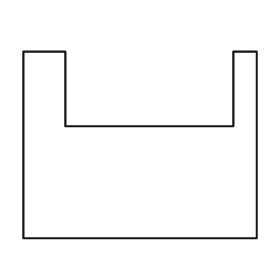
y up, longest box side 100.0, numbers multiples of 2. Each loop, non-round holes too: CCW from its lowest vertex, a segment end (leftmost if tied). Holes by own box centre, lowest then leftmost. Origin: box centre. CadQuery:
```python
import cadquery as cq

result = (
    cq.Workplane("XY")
    .moveTo(-50.0, -40.0)
    .lineTo(50.0, -40.0)
    .lineTo(50.0, 40.0)
    .lineTo(40.0, 40.0)
    .lineTo(40.0, 8.0)
    .lineTo(-32.0, 8.0)
    .lineTo(-32.0, 40.0)
    .lineTo(-50.0, 40.0)
    .close()
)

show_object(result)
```